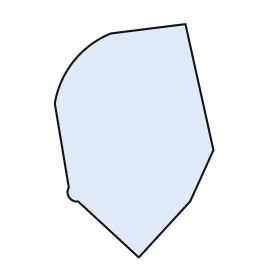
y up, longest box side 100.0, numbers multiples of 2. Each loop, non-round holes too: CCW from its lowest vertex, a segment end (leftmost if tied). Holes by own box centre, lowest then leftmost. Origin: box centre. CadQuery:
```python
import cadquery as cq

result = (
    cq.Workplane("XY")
    .moveTo(2.0, -50.0)
    .lineTo(24.0, -26.0)
    .lineTo(34.0, -4.0)
    .lineTo(22.0, 50.0)
    .lineTo(-10.0, 46.0)
    .threePointArc((-26.0, 34.0), (-34.0, 16.0))
    .lineTo(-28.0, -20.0)
    .threePointArc((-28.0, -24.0), (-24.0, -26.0))
    .close()
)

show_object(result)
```